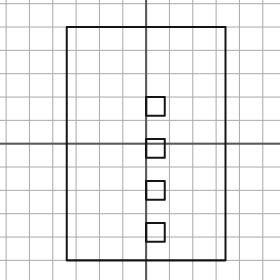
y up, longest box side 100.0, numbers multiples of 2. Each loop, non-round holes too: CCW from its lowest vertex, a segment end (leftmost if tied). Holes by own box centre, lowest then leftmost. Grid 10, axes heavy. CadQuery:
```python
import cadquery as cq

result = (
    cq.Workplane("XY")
    .moveTo(-34.0, -50.0)
    .lineTo(34.0, -50.0)
    .lineTo(34.0, 50.0)
    .lineTo(-34.0, 50.0)
    .close()
    .moveTo(0.0, -42.0)
    .lineTo(8.0, -42.0)
    .lineTo(8.0, -34.0)
    .lineTo(0.0, -34.0)
    .close()
    .moveTo(0.0, -24.0)
    .lineTo(8.0, -24.0)
    .lineTo(8.0, -16.0)
    .lineTo(0.0, -16.0)
    .close()
    .moveTo(0.0, -6.0)
    .lineTo(8.0, -6.0)
    .lineTo(8.0, 2.0)
    .lineTo(0.0, 2.0)
    .close()
    .moveTo(0.0, 12.0)
    .lineTo(8.0, 12.0)
    .lineTo(8.0, 20.0)
    .lineTo(0.0, 20.0)
    .close()
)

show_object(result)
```